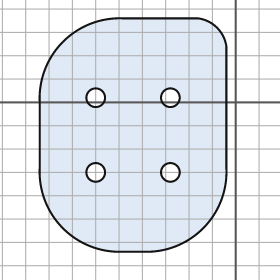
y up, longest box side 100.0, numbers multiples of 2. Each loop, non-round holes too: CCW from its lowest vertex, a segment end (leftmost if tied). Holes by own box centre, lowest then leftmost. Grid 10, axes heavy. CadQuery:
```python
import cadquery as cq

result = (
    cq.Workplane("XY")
    .moveTo(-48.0, -64.0)
    .lineTo(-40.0, -64.0)
    .threePointArc((-14.0, -54.0), (-4.0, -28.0))
    .lineTo(-4.0, 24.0)
    .threePointArc((-8.0, 32.0), (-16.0, 36.0))
    .lineTo(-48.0, 36.0)
    .threePointArc((-74.0, 26.0), (-84.0, 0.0))
    .lineTo(-84.0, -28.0)
    .threePointArc((-74.0, -54.0), (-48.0, -64.0))
    .close()
    .moveTo(-60.0, -30.0)
    .circle(4.0)
    .moveTo(-28.0, -30.0)
    .circle(4.0)
    .moveTo(-60.0, 2.0)
    .circle(4.0)
    .moveTo(-28.0, 2.0)
    .circle(4.0)
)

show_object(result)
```